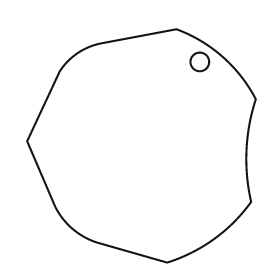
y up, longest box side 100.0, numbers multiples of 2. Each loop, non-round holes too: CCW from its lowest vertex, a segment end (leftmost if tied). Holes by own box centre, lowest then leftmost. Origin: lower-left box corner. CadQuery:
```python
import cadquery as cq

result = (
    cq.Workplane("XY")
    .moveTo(60.0, 0.0)
    .threePointArc((80.0, 10.0), (96.0, 26.0))
    .threePointArc((94.0, 48.0), (98.0, 70.0))
    .threePointArc((84.0, 88.0), (64.0, 100.0))
    .lineTo(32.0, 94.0)
    .threePointArc((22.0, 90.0), (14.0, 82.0))
    .lineTo(0.0, 52.0)
    .lineTo(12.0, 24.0)
    .threePointArc((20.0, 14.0), (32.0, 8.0))
    .close()
    .moveTo(74.0, 86.0)
    .circle(4.0)
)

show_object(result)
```